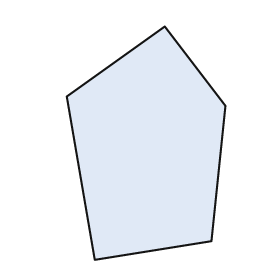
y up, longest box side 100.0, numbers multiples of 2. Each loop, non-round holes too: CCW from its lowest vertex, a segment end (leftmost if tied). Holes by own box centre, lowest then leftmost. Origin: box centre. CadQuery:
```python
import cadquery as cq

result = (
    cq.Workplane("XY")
    .moveTo(-22.0, -50.0)
    .lineTo(28.0, -42.0)
    .lineTo(34.0, 16.0)
    .lineTo(8.0, 50.0)
    .lineTo(-34.0, 20.0)
    .close()
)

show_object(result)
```